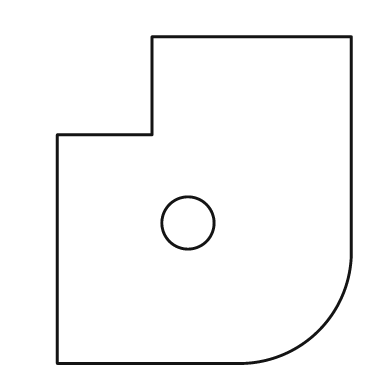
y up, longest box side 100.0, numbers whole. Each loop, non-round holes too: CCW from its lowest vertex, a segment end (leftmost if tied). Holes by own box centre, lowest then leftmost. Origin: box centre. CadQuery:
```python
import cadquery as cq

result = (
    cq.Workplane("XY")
    .moveTo(-45.0, -50.0)
    .lineTo(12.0, -50.0)
    .threePointArc((35.0, -40.0), (45.0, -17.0))
    .lineTo(45.0, 50.0)
    .lineTo(-16.0, 50.0)
    .lineTo(-16.0, 20.0)
    .lineTo(-45.0, 20.0)
    .close()
    .moveTo(-5.0, -7.0)
    .circle(8.0)
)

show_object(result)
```